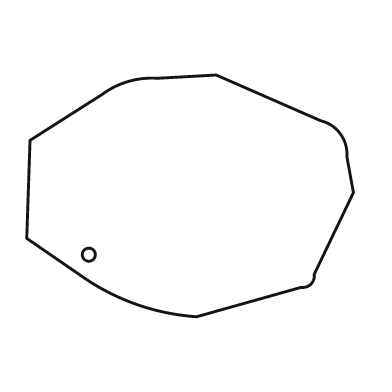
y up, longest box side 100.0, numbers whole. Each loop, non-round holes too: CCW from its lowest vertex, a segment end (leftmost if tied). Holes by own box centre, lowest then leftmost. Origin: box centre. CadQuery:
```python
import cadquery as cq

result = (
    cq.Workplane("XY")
    .moveTo(2.0, -37.0)
    .lineTo(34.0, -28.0)
    .threePointArc((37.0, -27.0), (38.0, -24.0))
    .lineTo(50.0, 1.0)
    .lineTo(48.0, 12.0)
    .threePointArc((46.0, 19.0), (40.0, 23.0))
    .lineTo(8.0, 37.0)
    .lineTo(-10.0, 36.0)
    .threePointArc((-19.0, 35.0), (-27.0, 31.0))
    .lineTo(-49.0, 17.0)
    .lineTo(-50.0, -13.0)
    .lineTo(-34.0, -24.0)
    .threePointArc((-17.0, -33.0), (2.0, -37.0))
    .close()
    .moveTo(-31.0, -18.0)
    .circle(2.0)
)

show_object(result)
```